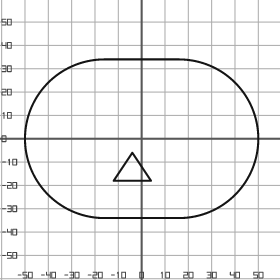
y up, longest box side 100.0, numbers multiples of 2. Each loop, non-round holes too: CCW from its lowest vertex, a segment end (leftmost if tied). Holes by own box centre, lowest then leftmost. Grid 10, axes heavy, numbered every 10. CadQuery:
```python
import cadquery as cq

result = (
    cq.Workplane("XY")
    .moveTo(-16.0, -34.0)
    .lineTo(16.0, -34.0)
    .threePointArc((50.0, 0.0), (16.0, 34.0))
    .lineTo(-16.0, 34.0)
    .threePointArc((-50.0, 0.0), (-16.0, -34.0))
    .close()
    .moveTo(-12.0, -18.0)
    .lineTo(4.0, -18.0)
    .lineTo(-4.0, -6.0)
    .close()
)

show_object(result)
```